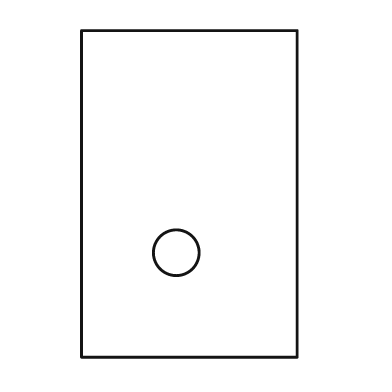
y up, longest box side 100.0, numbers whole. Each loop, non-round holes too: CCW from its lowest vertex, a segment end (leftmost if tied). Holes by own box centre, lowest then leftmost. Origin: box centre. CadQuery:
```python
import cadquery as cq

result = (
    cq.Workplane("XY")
    .moveTo(-33.0, -50.0)
    .lineTo(33.0, -50.0)
    .lineTo(33.0, 50.0)
    .lineTo(-33.0, 50.0)
    .close()
    .moveTo(-4.0, -18.0)
    .circle(7.0)
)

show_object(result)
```